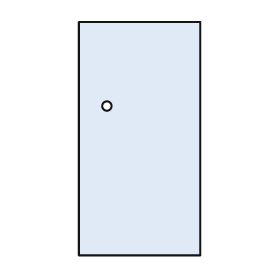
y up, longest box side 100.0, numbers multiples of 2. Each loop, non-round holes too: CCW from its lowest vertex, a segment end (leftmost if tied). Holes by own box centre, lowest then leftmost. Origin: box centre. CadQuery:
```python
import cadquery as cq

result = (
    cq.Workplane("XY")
    .moveTo(-26.0, -50.0)
    .lineTo(26.0, -50.0)
    .lineTo(26.0, 50.0)
    .lineTo(-26.0, 50.0)
    .close()
    .moveTo(-14.0, 14.0)
    .circle(2.0)
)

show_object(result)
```